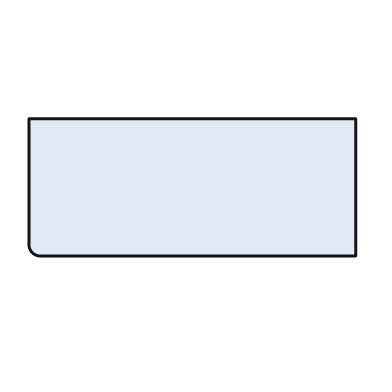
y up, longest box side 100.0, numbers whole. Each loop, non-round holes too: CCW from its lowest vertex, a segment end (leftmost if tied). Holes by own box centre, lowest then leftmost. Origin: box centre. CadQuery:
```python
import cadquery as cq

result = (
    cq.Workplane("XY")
    .moveTo(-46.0, -21.0)
    .lineTo(50.0, -21.0)
    .lineTo(50.0, 21.0)
    .lineTo(-50.0, 21.0)
    .lineTo(-50.0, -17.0)
    .threePointArc((-49.0, -20.0), (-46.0, -21.0))
    .close()
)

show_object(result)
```